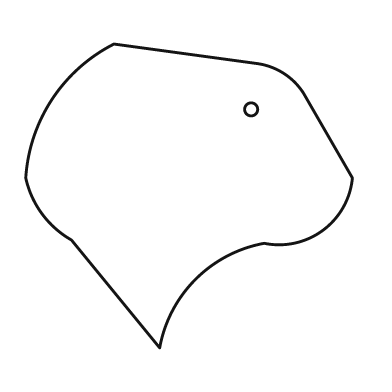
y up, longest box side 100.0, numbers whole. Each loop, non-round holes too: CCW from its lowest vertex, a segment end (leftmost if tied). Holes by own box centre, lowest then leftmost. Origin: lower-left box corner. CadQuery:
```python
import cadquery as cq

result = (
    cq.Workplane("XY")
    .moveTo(41.0, 0.0)
    .threePointArc((52.0, 21.0), (73.0, 32.0))
    .threePointArc((91.0, 36.0), (100.0, 52.0))
    .lineTo(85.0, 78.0)
    .threePointArc((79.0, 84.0), (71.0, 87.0))
    .lineTo(27.0, 93.0)
    .threePointArc((8.0, 76.0), (0.0, 52.0))
    .threePointArc((5.0, 41.0), (14.0, 33.0))
    .close()
    .moveTo(69.0, 73.0)
    .circle(2.0)
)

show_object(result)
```